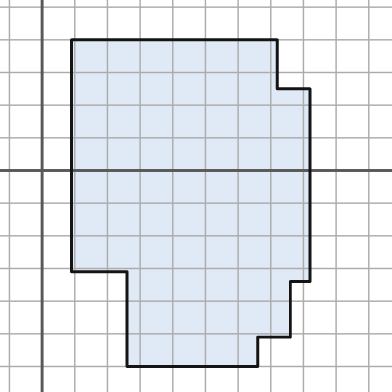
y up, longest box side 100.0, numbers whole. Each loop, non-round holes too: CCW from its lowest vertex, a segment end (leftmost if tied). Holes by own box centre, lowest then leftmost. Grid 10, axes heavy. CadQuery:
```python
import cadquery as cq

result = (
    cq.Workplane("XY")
    .moveTo(26.0, -60.0)
    .lineTo(66.0, -60.0)
    .lineTo(66.0, -51.0)
    .lineTo(76.0, -51.0)
    .lineTo(76.0, -34.0)
    .lineTo(82.0, -34.0)
    .lineTo(82.0, 25.0)
    .lineTo(72.0, 25.0)
    .lineTo(72.0, 40.0)
    .lineTo(9.0, 40.0)
    .lineTo(9.0, -31.0)
    .lineTo(26.0, -31.0)
    .close()
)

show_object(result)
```